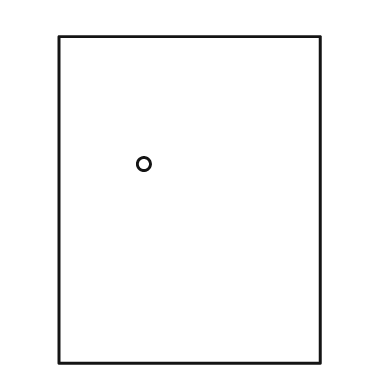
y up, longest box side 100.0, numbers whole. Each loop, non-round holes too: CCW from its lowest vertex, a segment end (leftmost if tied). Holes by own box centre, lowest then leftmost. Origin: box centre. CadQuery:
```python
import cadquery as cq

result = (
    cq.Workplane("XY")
    .moveTo(-40.0, -50.0)
    .lineTo(40.0, -50.0)
    .lineTo(40.0, 50.0)
    .lineTo(-40.0, 50.0)
    .close()
    .moveTo(-14.0, 11.0)
    .circle(2.0)
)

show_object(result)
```